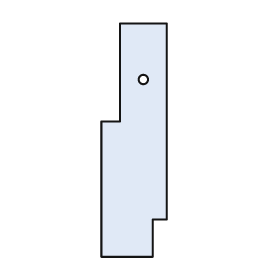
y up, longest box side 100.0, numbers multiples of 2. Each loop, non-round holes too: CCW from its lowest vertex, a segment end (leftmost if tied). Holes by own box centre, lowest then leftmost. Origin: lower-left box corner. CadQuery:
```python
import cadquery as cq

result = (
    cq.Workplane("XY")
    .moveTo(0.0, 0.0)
    .lineTo(22.0, 0.0)
    .lineTo(22.0, 16.0)
    .lineTo(28.0, 16.0)
    .lineTo(28.0, 100.0)
    .lineTo(8.0, 100.0)
    .lineTo(8.0, 58.0)
    .lineTo(0.0, 58.0)
    .close()
    .moveTo(18.0, 76.0)
    .circle(2.0)
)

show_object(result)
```